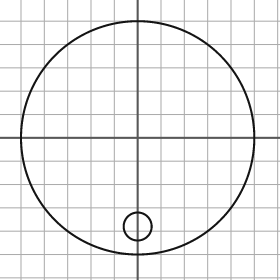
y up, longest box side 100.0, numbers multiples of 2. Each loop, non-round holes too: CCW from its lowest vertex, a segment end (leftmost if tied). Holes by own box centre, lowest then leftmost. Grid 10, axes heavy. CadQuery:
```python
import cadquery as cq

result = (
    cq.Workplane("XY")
    .moveTo(0.0, 0.0)
    .circle(50.0)
    .moveTo(0.0, -38.0)
    .circle(6.0)
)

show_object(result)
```